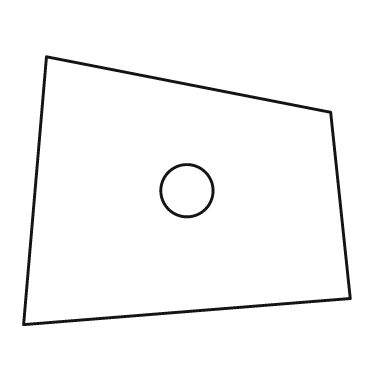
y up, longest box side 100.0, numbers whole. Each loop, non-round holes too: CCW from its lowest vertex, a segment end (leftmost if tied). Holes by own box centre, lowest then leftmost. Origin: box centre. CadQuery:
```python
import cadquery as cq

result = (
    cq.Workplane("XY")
    .moveTo(-50.0, -41.0)
    .lineTo(50.0, -33.0)
    .lineTo(44.0, 24.0)
    .lineTo(-43.0, 41.0)
    .close()
    .moveTo(0.0, 0.0)
    .circle(8.0)
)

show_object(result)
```